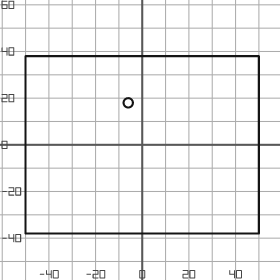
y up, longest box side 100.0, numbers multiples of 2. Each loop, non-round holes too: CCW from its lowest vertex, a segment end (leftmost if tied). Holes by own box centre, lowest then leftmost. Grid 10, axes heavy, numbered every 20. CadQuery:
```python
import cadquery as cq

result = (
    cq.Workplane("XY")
    .moveTo(-50.0, -38.0)
    .lineTo(50.0, -38.0)
    .lineTo(50.0, 38.0)
    .lineTo(-50.0, 38.0)
    .close()
    .moveTo(-6.0, 18.0)
    .circle(2.0)
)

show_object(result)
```